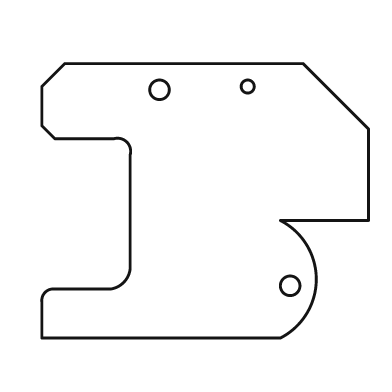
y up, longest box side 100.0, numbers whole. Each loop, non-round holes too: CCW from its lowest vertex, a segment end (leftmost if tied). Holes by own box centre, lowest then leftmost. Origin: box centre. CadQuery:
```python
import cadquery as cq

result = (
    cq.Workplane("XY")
    .moveTo(-50.0, -42.0)
    .lineTo(23.0, -42.0)
    .threePointArc((34.0, -24.0), (23.0, -6.0))
    .lineTo(50.0, -6.0)
    .lineTo(50.0, 22.0)
    .lineTo(30.0, 42.0)
    .lineTo(-43.0, 42.0)
    .lineTo(-50.0, 35.0)
    .lineTo(-50.0, 23.0)
    .lineTo(-46.0, 19.0)
    .lineTo(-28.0, 19.0)
    .threePointArc((-24.0, 18.0), (-23.0, 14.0))
    .lineTo(-23.0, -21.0)
    .threePointArc((-25.0, -25.0), (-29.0, -27.0))
    .lineTo(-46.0, -27.0)
    .threePointArc((-49.0, -28.0), (-50.0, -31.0))
    .close()
    .moveTo(26.0, -26.0)
    .circle(3.0)
    .moveTo(-14.0, 34.0)
    .circle(3.0)
    .moveTo(13.0, 35.0)
    .circle(2.0)
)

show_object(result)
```